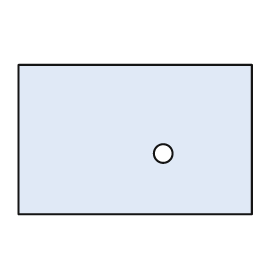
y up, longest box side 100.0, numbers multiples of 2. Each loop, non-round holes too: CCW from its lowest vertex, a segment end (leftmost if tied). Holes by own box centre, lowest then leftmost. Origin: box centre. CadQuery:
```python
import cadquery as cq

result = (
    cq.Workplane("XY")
    .moveTo(-50.0, -32.0)
    .lineTo(50.0, -32.0)
    .lineTo(50.0, 32.0)
    .lineTo(-50.0, 32.0)
    .close()
    .moveTo(12.0, -6.0)
    .circle(4.0)
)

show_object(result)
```